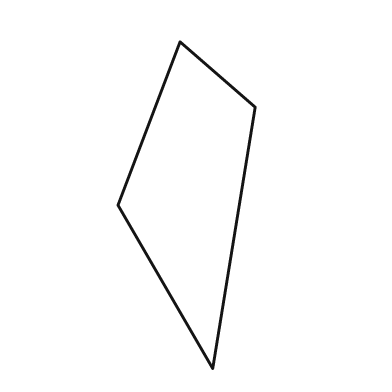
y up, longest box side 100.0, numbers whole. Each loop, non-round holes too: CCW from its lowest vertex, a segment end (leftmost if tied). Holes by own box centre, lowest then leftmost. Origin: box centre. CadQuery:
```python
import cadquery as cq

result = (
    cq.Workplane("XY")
    .moveTo(8.0, -50.0)
    .lineTo(21.0, 30.0)
    .lineTo(-2.0, 50.0)
    .lineTo(-21.0, 0.0)
    .close()
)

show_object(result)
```